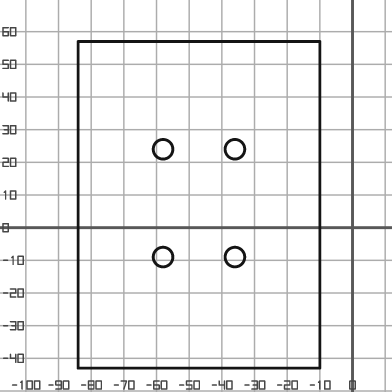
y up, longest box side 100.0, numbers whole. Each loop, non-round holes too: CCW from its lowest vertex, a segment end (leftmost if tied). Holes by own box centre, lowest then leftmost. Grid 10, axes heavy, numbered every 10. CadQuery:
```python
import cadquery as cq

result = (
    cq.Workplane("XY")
    .moveTo(-84.0, -43.0)
    .lineTo(-10.0, -43.0)
    .lineTo(-10.0, 57.0)
    .lineTo(-84.0, 57.0)
    .close()
    .moveTo(-58.0, -9.0)
    .circle(3.0)
    .moveTo(-36.0, -9.0)
    .circle(3.0)
    .moveTo(-58.0, 24.0)
    .circle(3.0)
    .moveTo(-36.0, 24.0)
    .circle(3.0)
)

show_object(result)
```